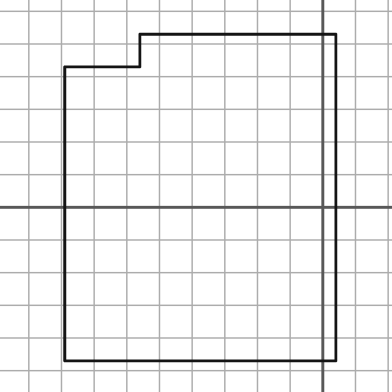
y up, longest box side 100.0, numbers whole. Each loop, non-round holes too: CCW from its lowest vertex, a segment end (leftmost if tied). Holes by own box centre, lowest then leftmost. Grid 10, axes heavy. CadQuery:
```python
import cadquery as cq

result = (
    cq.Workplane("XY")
    .moveTo(-79.0, -47.0)
    .lineTo(4.0, -47.0)
    .lineTo(4.0, 53.0)
    .lineTo(-56.0, 53.0)
    .lineTo(-56.0, 43.0)
    .lineTo(-79.0, 43.0)
    .close()
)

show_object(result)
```